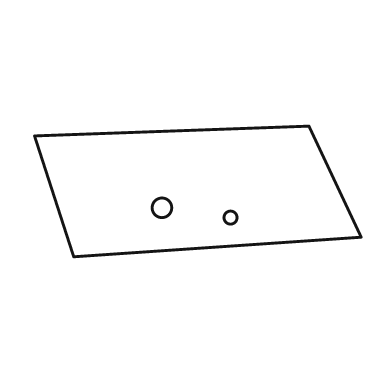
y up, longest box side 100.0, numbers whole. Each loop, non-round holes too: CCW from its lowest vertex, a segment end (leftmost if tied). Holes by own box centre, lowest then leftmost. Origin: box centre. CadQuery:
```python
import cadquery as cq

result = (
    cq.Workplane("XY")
    .moveTo(-38.0, -20.0)
    .lineTo(50.0, -14.0)
    .lineTo(34.0, 20.0)
    .lineTo(-50.0, 17.0)
    .close()
    .moveTo(10.0, -8.0)
    .circle(2.0)
    .moveTo(-11.0, -5.0)
    .circle(3.0)
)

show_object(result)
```